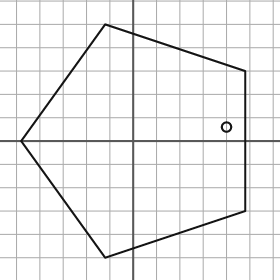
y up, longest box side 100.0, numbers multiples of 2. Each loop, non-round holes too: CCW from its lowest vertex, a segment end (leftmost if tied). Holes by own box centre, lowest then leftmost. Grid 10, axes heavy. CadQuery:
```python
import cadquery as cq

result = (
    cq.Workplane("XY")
    .moveTo(-12.0, -50.0)
    .lineTo(48.0, -30.0)
    .lineTo(48.0, 30.0)
    .lineTo(-12.0, 50.0)
    .lineTo(-48.0, 0.0)
    .close()
    .moveTo(40.0, 6.0)
    .circle(2.0)
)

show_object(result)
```